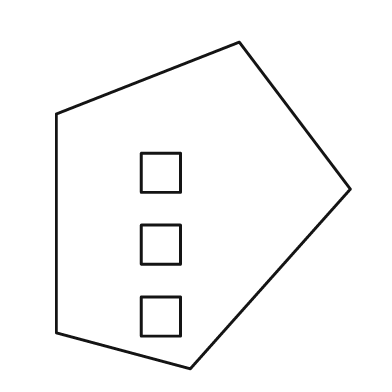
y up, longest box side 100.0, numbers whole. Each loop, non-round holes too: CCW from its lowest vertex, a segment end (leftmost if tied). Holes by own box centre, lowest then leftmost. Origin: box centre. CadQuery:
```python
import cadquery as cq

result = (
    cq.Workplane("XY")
    .moveTo(-4.0, -50.0)
    .lineTo(45.0, 5.0)
    .lineTo(11.0, 50.0)
    .lineTo(-45.0, 28.0)
    .lineTo(-45.0, -39.0)
    .close()
    .moveTo(-19.0, -40.0)
    .lineTo(-7.0, -40.0)
    .lineTo(-7.0, -28.0)
    .lineTo(-19.0, -28.0)
    .close()
    .moveTo(-19.0, -18.0)
    .lineTo(-7.0, -18.0)
    .lineTo(-7.0, -6.0)
    .lineTo(-19.0, -6.0)
    .close()
    .moveTo(-19.0, 4.0)
    .lineTo(-7.0, 4.0)
    .lineTo(-7.0, 16.0)
    .lineTo(-19.0, 16.0)
    .close()
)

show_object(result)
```